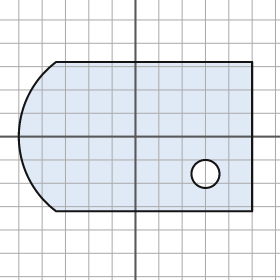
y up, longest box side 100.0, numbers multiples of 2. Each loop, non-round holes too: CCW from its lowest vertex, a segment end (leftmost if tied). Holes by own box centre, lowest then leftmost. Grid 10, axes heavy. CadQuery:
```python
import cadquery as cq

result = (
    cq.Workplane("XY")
    .moveTo(-34.0, -32.0)
    .lineTo(50.0, -32.0)
    .lineTo(50.0, 32.0)
    .lineTo(-34.0, 32.0)
    .threePointArc((-50.0, 0.0), (-34.0, -32.0))
    .close()
    .moveTo(30.0, -16.0)
    .circle(6.0)
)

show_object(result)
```